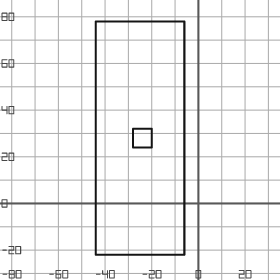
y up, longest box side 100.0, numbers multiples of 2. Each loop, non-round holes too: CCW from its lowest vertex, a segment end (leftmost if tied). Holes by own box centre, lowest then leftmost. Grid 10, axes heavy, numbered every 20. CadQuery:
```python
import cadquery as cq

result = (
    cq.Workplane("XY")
    .moveTo(-44.0, -22.0)
    .lineTo(-6.0, -22.0)
    .lineTo(-6.0, 78.0)
    .lineTo(-44.0, 78.0)
    .close()
    .moveTo(-28.0, 24.0)
    .lineTo(-20.0, 24.0)
    .lineTo(-20.0, 32.0)
    .lineTo(-28.0, 32.0)
    .close()
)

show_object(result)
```